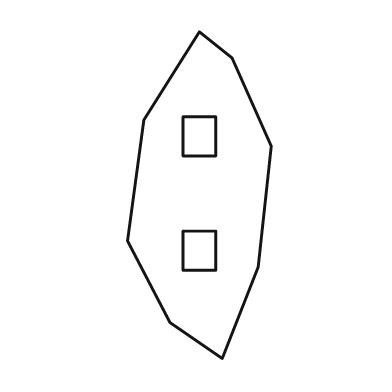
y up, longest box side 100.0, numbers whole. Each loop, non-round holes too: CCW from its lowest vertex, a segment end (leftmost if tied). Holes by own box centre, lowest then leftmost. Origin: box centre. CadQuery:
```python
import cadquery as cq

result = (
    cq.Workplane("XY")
    .moveTo(7.0, -50.0)
    .lineTo(18.0, -22.0)
    .lineTo(22.0, 15.0)
    .lineTo(10.0, 42.0)
    .lineTo(0.0, 50.0)
    .lineTo(-17.0, 23.0)
    .lineTo(-22.0, -14.0)
    .lineTo(-9.0, -39.0)
    .close()
    .moveTo(-5.0, -23.0)
    .lineTo(5.0, -23.0)
    .lineTo(5.0, -11.0)
    .lineTo(-5.0, -11.0)
    .close()
    .moveTo(-5.0, 12.0)
    .lineTo(5.0, 12.0)
    .lineTo(5.0, 24.0)
    .lineTo(-5.0, 24.0)
    .close()
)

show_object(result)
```